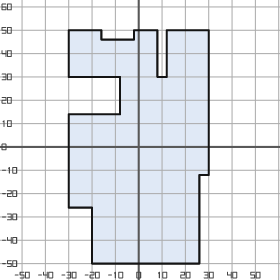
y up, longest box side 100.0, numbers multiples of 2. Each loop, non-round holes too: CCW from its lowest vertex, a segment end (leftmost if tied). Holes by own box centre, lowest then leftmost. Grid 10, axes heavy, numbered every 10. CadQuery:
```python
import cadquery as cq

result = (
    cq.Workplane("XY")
    .moveTo(-20.0, -50.0)
    .lineTo(26.0, -50.0)
    .lineTo(26.0, -12.0)
    .lineTo(30.0, -12.0)
    .lineTo(30.0, 50.0)
    .lineTo(12.0, 50.0)
    .lineTo(12.0, 30.0)
    .lineTo(8.0, 30.0)
    .lineTo(8.0, 50.0)
    .lineTo(-2.0, 50.0)
    .lineTo(-2.0, 46.0)
    .lineTo(-16.0, 46.0)
    .lineTo(-16.0, 50.0)
    .lineTo(-30.0, 50.0)
    .lineTo(-30.0, 30.0)
    .lineTo(-8.0, 30.0)
    .lineTo(-8.0, 14.0)
    .lineTo(-30.0, 14.0)
    .lineTo(-30.0, -26.0)
    .lineTo(-20.0, -26.0)
    .close()
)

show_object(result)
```